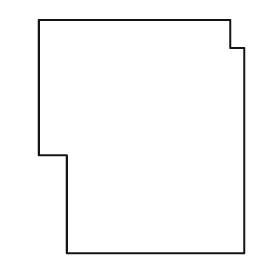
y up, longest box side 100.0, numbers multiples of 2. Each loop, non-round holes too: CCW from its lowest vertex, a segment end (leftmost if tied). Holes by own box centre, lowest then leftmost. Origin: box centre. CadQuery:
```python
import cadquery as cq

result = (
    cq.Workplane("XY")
    .moveTo(-32.0, -50.0)
    .lineTo(44.0, -50.0)
    .lineTo(44.0, 38.0)
    .lineTo(38.0, 38.0)
    .lineTo(38.0, 50.0)
    .lineTo(-44.0, 50.0)
    .lineTo(-44.0, -8.0)
    .lineTo(-32.0, -8.0)
    .close()
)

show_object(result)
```